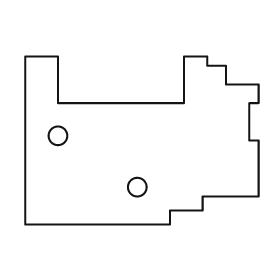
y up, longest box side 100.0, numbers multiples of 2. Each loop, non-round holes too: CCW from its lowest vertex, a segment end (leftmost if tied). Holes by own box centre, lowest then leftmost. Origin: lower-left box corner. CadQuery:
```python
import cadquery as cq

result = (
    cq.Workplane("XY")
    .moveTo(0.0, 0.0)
    .lineTo(62.0, 0.0)
    .lineTo(62.0, 6.0)
    .lineTo(76.0, 6.0)
    .lineTo(76.0, 12.0)
    .lineTo(100.0, 12.0)
    .lineTo(100.0, 36.0)
    .lineTo(96.0, 36.0)
    .lineTo(96.0, 52.0)
    .lineTo(100.0, 52.0)
    .lineTo(100.0, 60.0)
    .lineTo(86.0, 60.0)
    .lineTo(86.0, 68.0)
    .lineTo(78.0, 68.0)
    .lineTo(78.0, 72.0)
    .lineTo(68.0, 72.0)
    .lineTo(68.0, 52.0)
    .lineTo(14.0, 52.0)
    .lineTo(14.0, 72.0)
    .lineTo(0.0, 72.0)
    .close()
    .moveTo(48.0, 16.0)
    .circle(4.0)
    .moveTo(14.0, 38.0)
    .circle(4.0)
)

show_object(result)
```